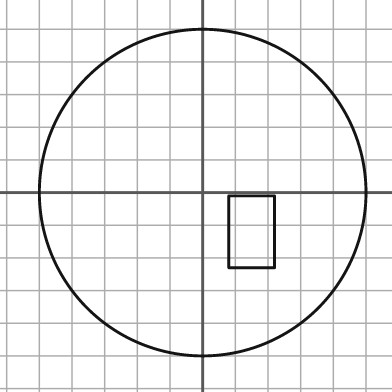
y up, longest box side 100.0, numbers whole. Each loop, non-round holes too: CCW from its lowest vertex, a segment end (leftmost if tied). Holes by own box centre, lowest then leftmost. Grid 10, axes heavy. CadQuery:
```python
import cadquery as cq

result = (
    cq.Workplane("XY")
    .moveTo(0.0, 0.0)
    .circle(50.0)
    .moveTo(8.0, -23.0)
    .lineTo(22.0, -23.0)
    .lineTo(22.0, -1.0)
    .lineTo(8.0, -1.0)
    .close()
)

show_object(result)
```